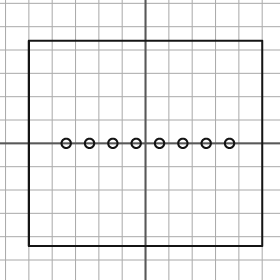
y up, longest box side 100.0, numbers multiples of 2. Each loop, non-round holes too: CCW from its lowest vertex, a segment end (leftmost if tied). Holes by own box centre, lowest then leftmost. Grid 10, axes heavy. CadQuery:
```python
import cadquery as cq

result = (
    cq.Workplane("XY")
    .moveTo(-50.0, -44.0)
    .lineTo(50.0, -44.0)
    .lineTo(50.0, 44.0)
    .lineTo(-50.0, 44.0)
    .close()
    .moveTo(-34.0, 0.0)
    .circle(2.0)
    .moveTo(-24.0, 0.0)
    .circle(2.0)
    .moveTo(-14.0, 0.0)
    .circle(2.0)
    .moveTo(-4.0, 0.0)
    .circle(2.0)
    .moveTo(6.0, 0.0)
    .circle(2.0)
    .moveTo(16.0, 0.0)
    .circle(2.0)
    .moveTo(26.0, 0.0)
    .circle(2.0)
    .moveTo(36.0, 0.0)
    .circle(2.0)
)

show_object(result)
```